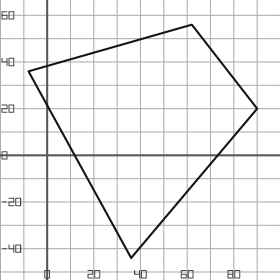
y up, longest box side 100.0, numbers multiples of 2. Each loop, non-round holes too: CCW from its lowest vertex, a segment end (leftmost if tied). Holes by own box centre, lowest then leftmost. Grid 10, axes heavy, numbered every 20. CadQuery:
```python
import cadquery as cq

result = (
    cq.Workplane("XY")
    .moveTo(36.0, -44.0)
    .lineTo(90.0, 20.0)
    .lineTo(62.0, 56.0)
    .lineTo(-8.0, 36.0)
    .close()
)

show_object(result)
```